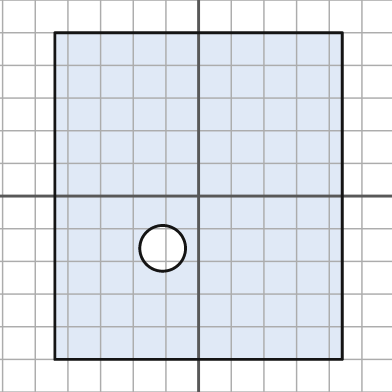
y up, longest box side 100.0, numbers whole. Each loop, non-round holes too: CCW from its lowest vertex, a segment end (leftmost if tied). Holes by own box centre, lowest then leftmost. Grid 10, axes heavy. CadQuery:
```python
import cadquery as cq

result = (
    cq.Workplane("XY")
    .moveTo(-44.0, -50.0)
    .lineTo(44.0, -50.0)
    .lineTo(44.0, 50.0)
    .lineTo(-44.0, 50.0)
    .close()
    .moveTo(-11.0, -16.0)
    .circle(7.0)
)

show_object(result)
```